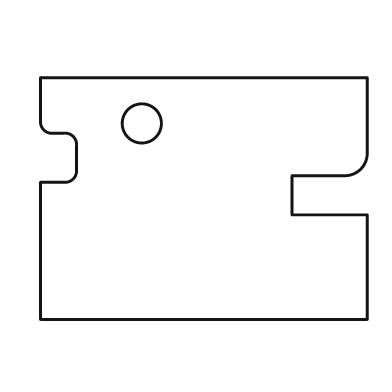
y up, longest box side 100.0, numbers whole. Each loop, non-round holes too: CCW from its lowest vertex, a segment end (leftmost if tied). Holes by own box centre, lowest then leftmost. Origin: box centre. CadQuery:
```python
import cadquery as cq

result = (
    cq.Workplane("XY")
    .moveTo(-50.0, -37.0)
    .lineTo(50.0, -37.0)
    .lineTo(50.0, -5.0)
    .lineTo(27.0, -5.0)
    .lineTo(27.0, 7.0)
    .lineTo(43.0, 7.0)
    .threePointArc((48.0, 9.0), (50.0, 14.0))
    .lineTo(50.0, 37.0)
    .lineTo(-50.0, 37.0)
    .lineTo(-50.0, 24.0)
    .threePointArc((-49.0, 21.0), (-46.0, 20.0))
    .lineTo(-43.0, 20.0)
    .threePointArc((-40.0, 19.0), (-39.0, 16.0))
    .lineTo(-39.0, 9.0)
    .threePointArc((-40.0, 6.0), (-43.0, 5.0))
    .lineTo(-50.0, 5.0)
    .close()
    .moveTo(-19.0, 23.0)
    .circle(6.0)
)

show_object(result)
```